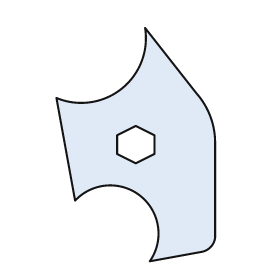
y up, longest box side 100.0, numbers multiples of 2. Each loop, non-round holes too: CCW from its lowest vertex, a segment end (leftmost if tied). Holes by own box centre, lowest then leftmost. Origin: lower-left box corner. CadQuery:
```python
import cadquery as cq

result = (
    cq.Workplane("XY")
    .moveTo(40.0, 0.0)
    .lineTo(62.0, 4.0)
    .threePointArc((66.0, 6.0), (68.0, 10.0))
    .lineTo(68.0, 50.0)
    .threePointArc((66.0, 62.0), (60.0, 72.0))
    .lineTo(38.0, 100.0)
    .threePointArc((28.0, 74.0), (0.0, 70.0))
    .lineTo(8.0, 26.0)
    .threePointArc((36.0, 28.0), (40.0, 0.0))
    .close()
    .moveTo(34.0, 42.0)
    .lineTo(42.0, 46.0)
    .lineTo(42.0, 54.0)
    .lineTo(34.0, 58.0)
    .lineTo(26.0, 54.0)
    .lineTo(26.0, 46.0)
    .close()
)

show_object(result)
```